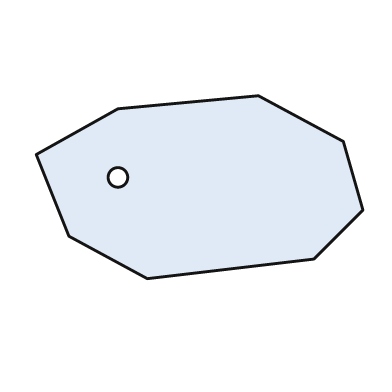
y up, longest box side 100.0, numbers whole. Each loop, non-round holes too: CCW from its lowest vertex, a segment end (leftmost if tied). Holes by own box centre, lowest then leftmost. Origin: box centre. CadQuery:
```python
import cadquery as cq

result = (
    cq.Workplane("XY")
    .moveTo(-16.0, -28.0)
    .lineTo(35.0, -22.0)
    .lineTo(50.0, -7.0)
    .lineTo(44.0, 14.0)
    .lineTo(18.0, 28.0)
    .lineTo(-25.0, 24.0)
    .lineTo(-50.0, 10.0)
    .lineTo(-40.0, -15.0)
    .close()
    .moveTo(-25.0, 3.0)
    .circle(3.0)
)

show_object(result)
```